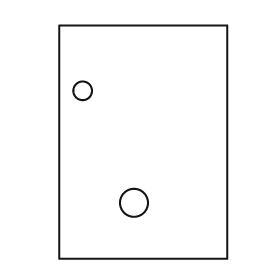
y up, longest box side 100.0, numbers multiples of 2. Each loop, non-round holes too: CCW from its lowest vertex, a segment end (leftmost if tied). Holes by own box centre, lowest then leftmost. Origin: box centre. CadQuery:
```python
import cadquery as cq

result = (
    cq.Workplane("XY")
    .moveTo(-36.0, -50.0)
    .lineTo(36.0, -50.0)
    .lineTo(36.0, 50.0)
    .lineTo(-36.0, 50.0)
    .close()
    .moveTo(-4.0, -26.0)
    .circle(6.0)
    .moveTo(-26.0, 22.0)
    .circle(4.0)
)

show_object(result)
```